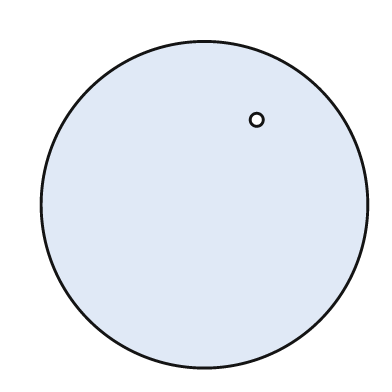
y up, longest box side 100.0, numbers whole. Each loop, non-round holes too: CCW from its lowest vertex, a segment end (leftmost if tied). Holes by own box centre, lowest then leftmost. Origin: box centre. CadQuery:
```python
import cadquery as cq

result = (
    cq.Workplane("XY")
    .moveTo(0.0, 0.0)
    .circle(50.0)
    .moveTo(16.0, 26.0)
    .circle(2.0)
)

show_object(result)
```